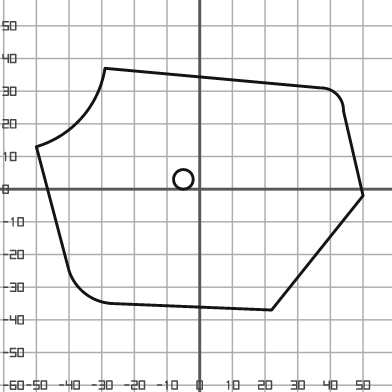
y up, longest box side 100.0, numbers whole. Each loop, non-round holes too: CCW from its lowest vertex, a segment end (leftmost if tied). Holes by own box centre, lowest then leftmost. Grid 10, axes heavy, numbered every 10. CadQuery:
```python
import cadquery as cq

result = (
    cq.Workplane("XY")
    .moveTo(22.0, -37.0)
    .lineTo(50.0, -2.0)
    .lineTo(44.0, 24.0)
    .threePointArc((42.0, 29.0), (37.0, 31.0))
    .lineTo(-29.0, 37.0)
    .threePointArc((-36.0, 22.0), (-50.0, 13.0))
    .lineTo(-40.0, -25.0)
    .threePointArc((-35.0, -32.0), (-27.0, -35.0))
    .close()
    .moveTo(-5.0, 3.0)
    .circle(3.0)
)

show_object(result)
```